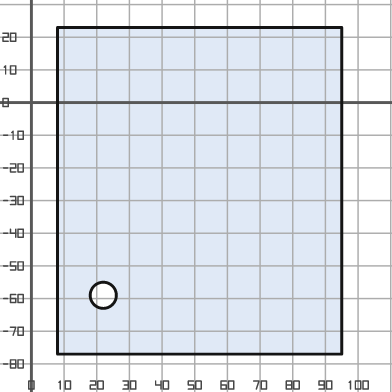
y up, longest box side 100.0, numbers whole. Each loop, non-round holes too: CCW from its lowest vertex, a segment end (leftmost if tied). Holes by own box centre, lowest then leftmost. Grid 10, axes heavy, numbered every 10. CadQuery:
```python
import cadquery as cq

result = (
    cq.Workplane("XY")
    .moveTo(8.0, -77.0)
    .lineTo(95.0, -77.0)
    .lineTo(95.0, 23.0)
    .lineTo(8.0, 23.0)
    .close()
    .moveTo(22.0, -59.0)
    .circle(4.0)
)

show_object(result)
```